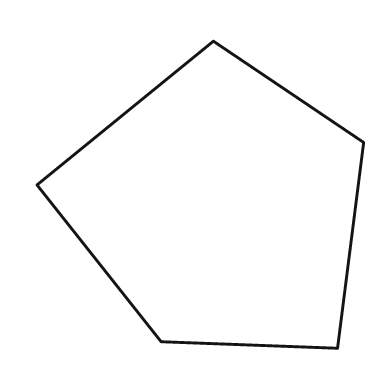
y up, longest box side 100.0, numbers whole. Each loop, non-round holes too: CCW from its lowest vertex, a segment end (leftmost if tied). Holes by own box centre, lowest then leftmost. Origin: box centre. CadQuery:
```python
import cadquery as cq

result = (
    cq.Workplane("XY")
    .moveTo(42.0, -47.0)
    .lineTo(50.0, 16.0)
    .lineTo(4.0, 47.0)
    .lineTo(-50.0, 3.0)
    .lineTo(-12.0, -45.0)
    .close()
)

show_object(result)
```